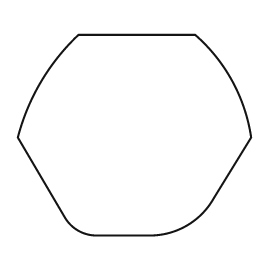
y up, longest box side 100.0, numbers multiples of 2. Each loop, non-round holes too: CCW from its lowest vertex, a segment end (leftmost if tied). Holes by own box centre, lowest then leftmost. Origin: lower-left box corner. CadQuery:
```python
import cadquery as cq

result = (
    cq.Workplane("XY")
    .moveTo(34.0, 0.0)
    .lineTo(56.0, 0.0)
    .threePointArc((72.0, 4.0), (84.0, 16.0))
    .lineTo(100.0, 42.0)
    .threePointArc((92.0, 66.0), (76.0, 86.0))
    .lineTo(26.0, 86.0)
    .threePointArc((10.0, 66.0), (0.0, 42.0))
    .lineTo(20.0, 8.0)
    .threePointArc((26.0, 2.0), (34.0, 0.0))
    .close()
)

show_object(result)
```